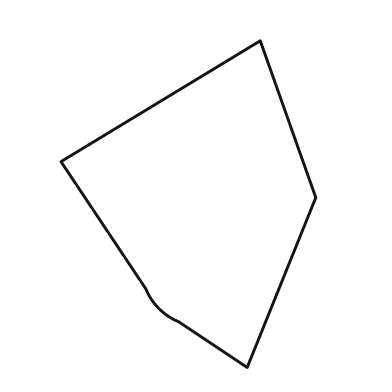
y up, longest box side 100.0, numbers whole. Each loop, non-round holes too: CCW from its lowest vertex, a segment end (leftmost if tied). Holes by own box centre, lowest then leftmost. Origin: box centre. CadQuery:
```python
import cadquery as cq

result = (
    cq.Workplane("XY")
    .moveTo(18.0, -50.0)
    .lineTo(39.0, 2.0)
    .lineTo(22.0, 50.0)
    .lineTo(-39.0, 13.0)
    .lineTo(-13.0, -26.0)
    .threePointArc((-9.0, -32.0), (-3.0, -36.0))
    .close()
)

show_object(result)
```